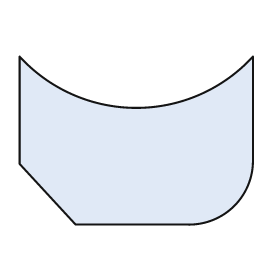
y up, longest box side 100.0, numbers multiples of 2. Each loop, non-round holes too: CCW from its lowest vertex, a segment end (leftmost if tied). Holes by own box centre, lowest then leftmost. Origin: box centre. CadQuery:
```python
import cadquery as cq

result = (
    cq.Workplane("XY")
    .moveTo(-26.0, -36.0)
    .lineTo(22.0, -36.0)
    .threePointArc((42.0, -28.0), (50.0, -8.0))
    .lineTo(50.0, 36.0)
    .threePointArc((0.0, 14.0), (-50.0, 36.0))
    .lineTo(-50.0, -10.0)
    .close()
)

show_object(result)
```